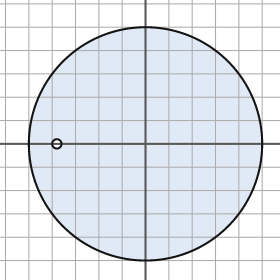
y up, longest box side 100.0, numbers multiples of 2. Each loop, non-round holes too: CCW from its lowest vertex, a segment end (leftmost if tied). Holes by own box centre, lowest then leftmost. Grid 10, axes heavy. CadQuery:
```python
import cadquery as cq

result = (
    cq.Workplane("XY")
    .moveTo(0.0, 0.0)
    .circle(50.0)
    .moveTo(-38.0, 0.0)
    .circle(2.0)
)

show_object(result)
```